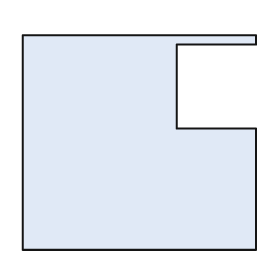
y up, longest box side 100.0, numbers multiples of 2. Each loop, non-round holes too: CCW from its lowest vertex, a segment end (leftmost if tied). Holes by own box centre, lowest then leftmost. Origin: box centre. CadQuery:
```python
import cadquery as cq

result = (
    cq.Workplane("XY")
    .moveTo(-50.0, -46.0)
    .lineTo(50.0, -46.0)
    .lineTo(50.0, 6.0)
    .lineTo(16.0, 6.0)
    .lineTo(16.0, 42.0)
    .lineTo(50.0, 42.0)
    .lineTo(50.0, 46.0)
    .lineTo(-50.0, 46.0)
    .close()
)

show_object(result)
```